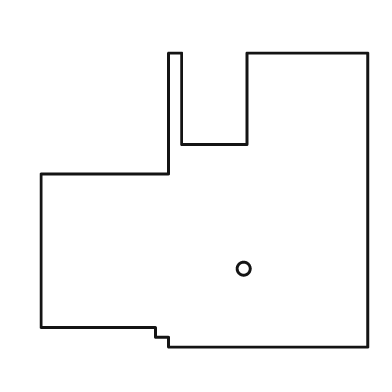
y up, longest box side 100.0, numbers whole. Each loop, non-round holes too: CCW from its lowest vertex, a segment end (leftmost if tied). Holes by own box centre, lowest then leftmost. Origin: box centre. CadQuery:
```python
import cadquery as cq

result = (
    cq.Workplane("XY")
    .moveTo(-11.0, -45.0)
    .lineTo(50.0, -45.0)
    .lineTo(50.0, 45.0)
    .lineTo(13.0, 45.0)
    .lineTo(13.0, 17.0)
    .lineTo(-7.0, 17.0)
    .lineTo(-7.0, 45.0)
    .lineTo(-11.0, 45.0)
    .lineTo(-11.0, 8.0)
    .lineTo(-50.0, 8.0)
    .lineTo(-50.0, -39.0)
    .lineTo(-15.0, -39.0)
    .lineTo(-15.0, -42.0)
    .lineTo(-11.0, -42.0)
    .close()
    .moveTo(12.0, -21.0)
    .circle(2.0)
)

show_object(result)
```